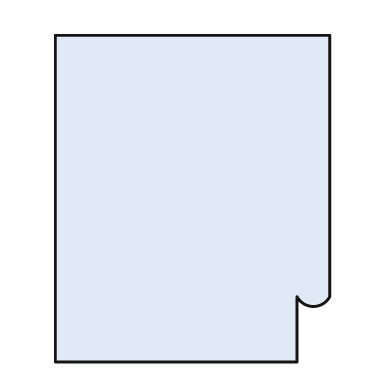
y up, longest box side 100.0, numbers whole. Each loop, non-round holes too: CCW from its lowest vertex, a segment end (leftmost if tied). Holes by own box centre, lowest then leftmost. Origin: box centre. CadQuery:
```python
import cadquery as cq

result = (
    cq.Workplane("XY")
    .moveTo(-42.0, -50.0)
    .lineTo(32.0, -50.0)
    .lineTo(32.0, -30.0)
    .threePointArc((37.0, -33.0), (42.0, -30.0))
    .lineTo(42.0, 50.0)
    .lineTo(-42.0, 50.0)
    .close()
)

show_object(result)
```